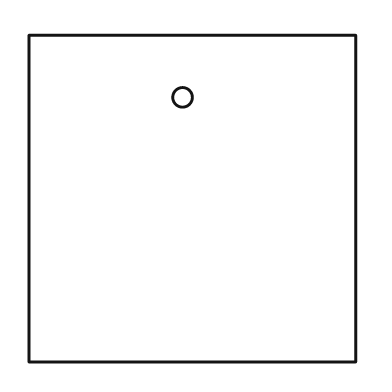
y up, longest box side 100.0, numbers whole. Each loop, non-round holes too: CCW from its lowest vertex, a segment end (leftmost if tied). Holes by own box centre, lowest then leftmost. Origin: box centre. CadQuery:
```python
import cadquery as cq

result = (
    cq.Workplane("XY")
    .moveTo(-50.0, -50.0)
    .lineTo(50.0, -50.0)
    .lineTo(50.0, 50.0)
    .lineTo(-50.0, 50.0)
    .close()
    .moveTo(-3.0, 31.0)
    .circle(3.0)
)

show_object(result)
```